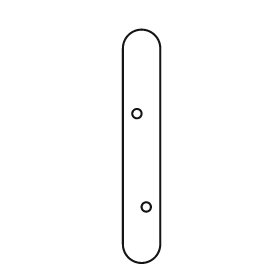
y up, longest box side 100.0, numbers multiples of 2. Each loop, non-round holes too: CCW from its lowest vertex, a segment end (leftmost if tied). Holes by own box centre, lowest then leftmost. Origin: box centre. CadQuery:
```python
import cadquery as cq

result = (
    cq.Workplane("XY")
    .moveTo(-8.0, -42.0)
    .threePointArc((0.0, -50.0), (8.0, -42.0))
    .lineTo(8.0, 42.0)
    .threePointArc((0.0, 50.0), (-8.0, 42.0))
    .close()
    .moveTo(2.0, -26.0)
    .circle(2.0)
    .moveTo(-2.0, 14.0)
    .circle(2.0)
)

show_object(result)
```